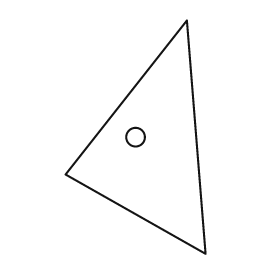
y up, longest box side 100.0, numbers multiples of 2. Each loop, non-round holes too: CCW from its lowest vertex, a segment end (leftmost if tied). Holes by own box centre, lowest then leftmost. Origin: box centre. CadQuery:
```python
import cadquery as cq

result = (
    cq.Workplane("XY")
    .moveTo(30.0, -50.0)
    .lineTo(22.0, 50.0)
    .lineTo(-30.0, -16.0)
    .close()
    .moveTo(0.0, 0.0)
    .circle(4.0)
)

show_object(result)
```